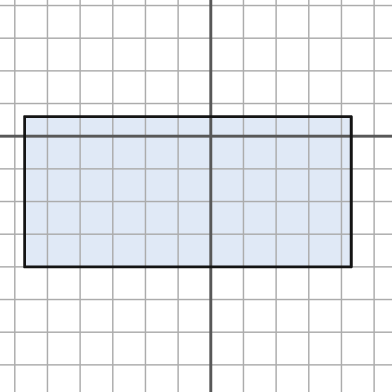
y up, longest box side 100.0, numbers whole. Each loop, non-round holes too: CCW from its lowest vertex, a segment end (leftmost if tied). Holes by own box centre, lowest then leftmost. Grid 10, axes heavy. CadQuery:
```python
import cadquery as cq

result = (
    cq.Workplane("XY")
    .moveTo(-57.0, -40.0)
    .lineTo(43.0, -40.0)
    .lineTo(43.0, 6.0)
    .lineTo(-57.0, 6.0)
    .close()
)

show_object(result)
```